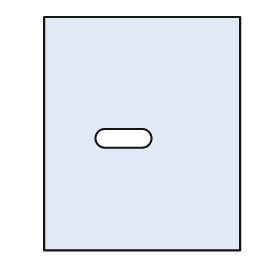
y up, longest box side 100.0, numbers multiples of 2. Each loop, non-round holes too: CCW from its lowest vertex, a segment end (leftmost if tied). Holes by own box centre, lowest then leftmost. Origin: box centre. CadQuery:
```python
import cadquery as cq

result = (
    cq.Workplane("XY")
    .moveTo(-42.0, -50.0)
    .lineTo(42.0, -50.0)
    .lineTo(42.0, 50.0)
    .lineTo(-42.0, 50.0)
    .close()
    .moveTo(-16.0, -6.0)
    .lineTo(0.0, -6.0)
    .threePointArc((4.0, -2.0), (0.0, 2.0))
    .lineTo(-16.0, 2.0)
    .threePointArc((-20.0, -2.0), (-16.0, -6.0))
    .close()
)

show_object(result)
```